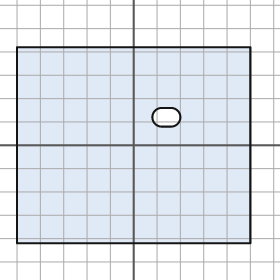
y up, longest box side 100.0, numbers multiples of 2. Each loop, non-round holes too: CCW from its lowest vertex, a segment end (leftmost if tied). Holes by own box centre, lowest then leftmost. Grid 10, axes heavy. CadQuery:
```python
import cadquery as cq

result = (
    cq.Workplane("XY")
    .moveTo(-50.0, -42.0)
    .lineTo(50.0, -42.0)
    .lineTo(50.0, 42.0)
    .lineTo(-50.0, 42.0)
    .close()
    .moveTo(12.0, 8.0)
    .lineTo(16.0, 8.0)
    .threePointArc((20.0, 12.0), (16.0, 16.0))
    .lineTo(12.0, 16.0)
    .threePointArc((8.0, 12.0), (12.0, 8.0))
    .close()
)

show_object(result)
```